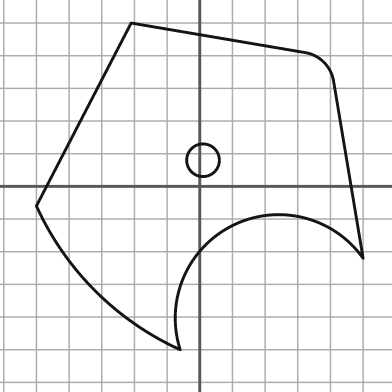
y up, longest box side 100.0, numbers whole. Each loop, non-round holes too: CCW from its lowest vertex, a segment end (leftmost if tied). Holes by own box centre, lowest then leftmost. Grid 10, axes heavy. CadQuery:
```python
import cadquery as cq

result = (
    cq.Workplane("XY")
    .moveTo(-6.0, -50.0)
    .threePointArc((10.0, -12.0), (50.0, -22.0))
    .lineTo(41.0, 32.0)
    .threePointArc((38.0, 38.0), (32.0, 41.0))
    .lineTo(-21.0, 50.0)
    .lineTo(-50.0, -6.0)
    .threePointArc((-32.0, -32.0), (-6.0, -50.0))
    .close()
    .moveTo(1.0, 8.0)
    .circle(5.0)
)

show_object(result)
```